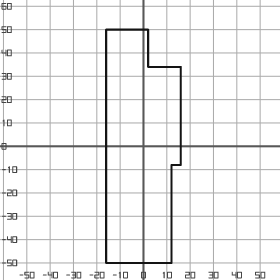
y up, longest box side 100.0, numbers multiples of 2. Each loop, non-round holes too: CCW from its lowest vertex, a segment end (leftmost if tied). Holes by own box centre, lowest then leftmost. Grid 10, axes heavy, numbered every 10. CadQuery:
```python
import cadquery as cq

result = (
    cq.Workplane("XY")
    .moveTo(-16.0, -50.0)
    .lineTo(12.0, -50.0)
    .lineTo(12.0, -8.0)
    .lineTo(16.0, -8.0)
    .lineTo(16.0, 34.0)
    .lineTo(2.0, 34.0)
    .lineTo(2.0, 50.0)
    .lineTo(-16.0, 50.0)
    .close()
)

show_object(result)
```